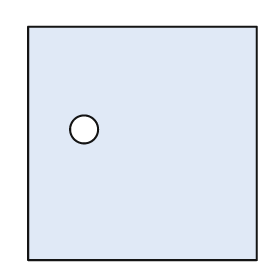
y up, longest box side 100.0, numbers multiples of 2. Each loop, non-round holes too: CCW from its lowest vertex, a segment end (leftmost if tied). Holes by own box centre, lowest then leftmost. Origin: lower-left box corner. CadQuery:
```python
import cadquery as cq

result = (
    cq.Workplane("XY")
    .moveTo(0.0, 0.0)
    .lineTo(98.0, 0.0)
    .lineTo(98.0, 100.0)
    .lineTo(0.0, 100.0)
    .close()
    .moveTo(24.0, 56.0)
    .circle(6.0)
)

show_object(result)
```